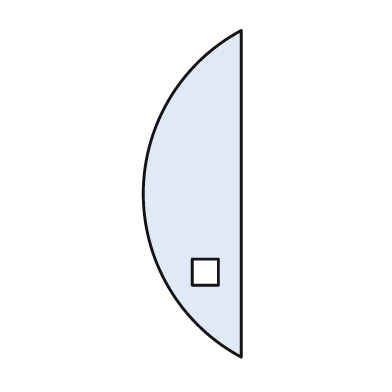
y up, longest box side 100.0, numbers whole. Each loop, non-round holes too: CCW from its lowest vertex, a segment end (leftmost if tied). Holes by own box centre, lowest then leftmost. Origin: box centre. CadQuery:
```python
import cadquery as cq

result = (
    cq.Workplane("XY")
    .moveTo(15.0, -50.0)
    .lineTo(15.0, 50.0)
    .threePointArc((-15.0, 0.0), (15.0, -50.0))
    .close()
    .moveTo(0.0, -28.0)
    .lineTo(8.0, -28.0)
    .lineTo(8.0, -20.0)
    .lineTo(0.0, -20.0)
    .close()
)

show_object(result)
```